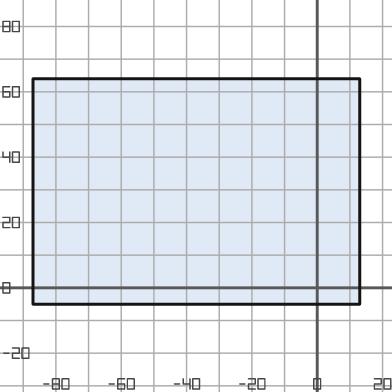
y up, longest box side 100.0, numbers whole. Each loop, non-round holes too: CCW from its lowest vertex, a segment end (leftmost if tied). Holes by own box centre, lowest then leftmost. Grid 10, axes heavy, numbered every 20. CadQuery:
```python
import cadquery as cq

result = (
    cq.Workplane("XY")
    .moveTo(-87.0, -5.0)
    .lineTo(13.0, -5.0)
    .lineTo(13.0, 64.0)
    .lineTo(-87.0, 64.0)
    .close()
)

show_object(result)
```